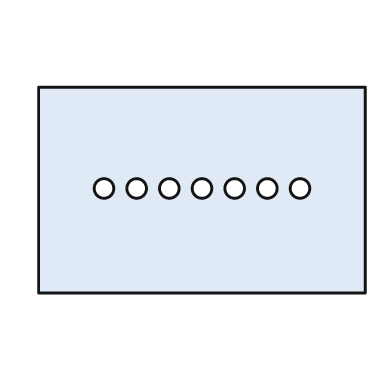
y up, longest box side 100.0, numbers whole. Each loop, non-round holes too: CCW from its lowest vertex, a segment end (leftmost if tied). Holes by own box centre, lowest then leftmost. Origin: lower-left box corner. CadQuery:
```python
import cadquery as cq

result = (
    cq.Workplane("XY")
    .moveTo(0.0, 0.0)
    .lineTo(100.0, 0.0)
    .lineTo(100.0, 63.0)
    .lineTo(0.0, 63.0)
    .close()
    .moveTo(20.0, 32.0)
    .circle(3.0)
    .moveTo(30.0, 32.0)
    .circle(3.0)
    .moveTo(40.0, 32.0)
    .circle(3.0)
    .moveTo(50.0, 32.0)
    .circle(3.0)
    .moveTo(60.0, 32.0)
    .circle(3.0)
    .moveTo(70.0, 32.0)
    .circle(3.0)
    .moveTo(80.0, 32.0)
    .circle(3.0)
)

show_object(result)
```